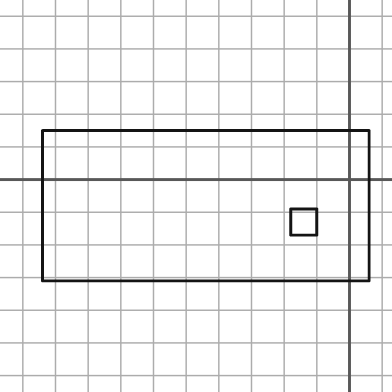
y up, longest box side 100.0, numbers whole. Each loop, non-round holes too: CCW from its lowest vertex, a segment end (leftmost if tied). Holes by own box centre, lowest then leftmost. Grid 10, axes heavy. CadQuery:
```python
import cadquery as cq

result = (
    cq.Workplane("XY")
    .moveTo(-94.0, -31.0)
    .lineTo(6.0, -31.0)
    .lineTo(6.0, 15.0)
    .lineTo(-94.0, 15.0)
    .close()
    .moveTo(-18.0, -17.0)
    .lineTo(-10.0, -17.0)
    .lineTo(-10.0, -9.0)
    .lineTo(-18.0, -9.0)
    .close()
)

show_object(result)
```